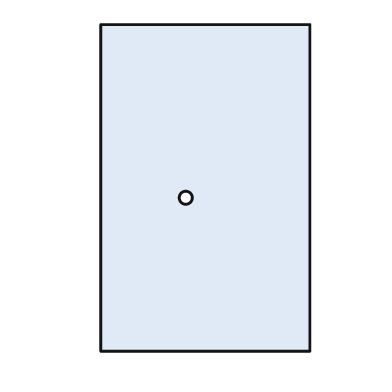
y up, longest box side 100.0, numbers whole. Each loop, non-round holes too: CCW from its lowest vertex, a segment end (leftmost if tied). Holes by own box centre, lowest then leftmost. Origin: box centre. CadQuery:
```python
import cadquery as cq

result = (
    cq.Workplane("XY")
    .moveTo(-32.0, -50.0)
    .lineTo(32.0, -50.0)
    .lineTo(32.0, 50.0)
    .lineTo(-32.0, 50.0)
    .close()
    .moveTo(-6.0, -3.0)
    .circle(2.0)
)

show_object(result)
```